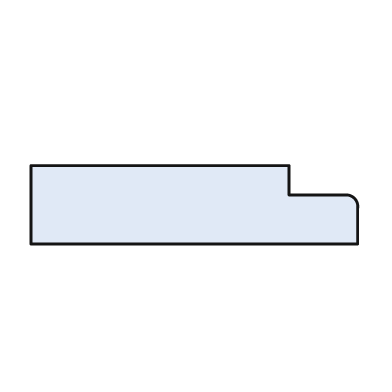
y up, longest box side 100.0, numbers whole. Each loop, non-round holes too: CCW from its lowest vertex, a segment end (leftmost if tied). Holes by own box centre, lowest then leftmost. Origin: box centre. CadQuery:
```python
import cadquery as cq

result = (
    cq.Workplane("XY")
    .moveTo(-50.0, -12.0)
    .lineTo(50.0, -12.0)
    .lineTo(50.0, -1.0)
    .threePointArc((49.0, 2.0), (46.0, 3.0))
    .lineTo(29.0, 3.0)
    .lineTo(29.0, 12.0)
    .lineTo(-50.0, 12.0)
    .close()
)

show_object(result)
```